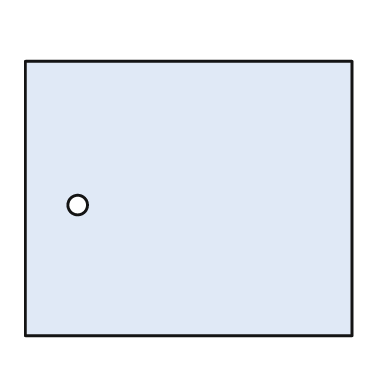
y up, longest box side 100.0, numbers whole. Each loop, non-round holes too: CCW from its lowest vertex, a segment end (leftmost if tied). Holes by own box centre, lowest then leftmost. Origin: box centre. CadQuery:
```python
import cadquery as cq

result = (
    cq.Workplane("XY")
    .moveTo(-50.0, -42.0)
    .lineTo(50.0, -42.0)
    .lineTo(50.0, 42.0)
    .lineTo(-50.0, 42.0)
    .close()
    .moveTo(-34.0, -2.0)
    .circle(3.0)
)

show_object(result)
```